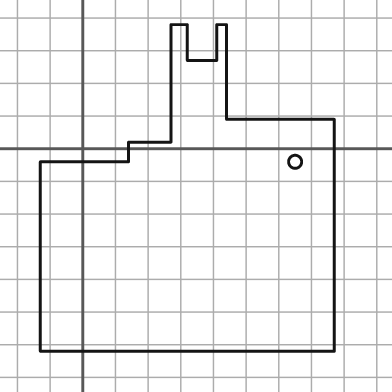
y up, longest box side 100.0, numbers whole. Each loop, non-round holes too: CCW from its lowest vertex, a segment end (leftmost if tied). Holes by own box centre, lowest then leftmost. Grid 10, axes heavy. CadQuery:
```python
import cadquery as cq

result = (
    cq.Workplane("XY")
    .moveTo(-13.0, -62.0)
    .lineTo(77.0, -62.0)
    .lineTo(77.0, 9.0)
    .lineTo(44.0, 9.0)
    .lineTo(44.0, 38.0)
    .lineTo(41.0, 38.0)
    .lineTo(41.0, 27.0)
    .lineTo(32.0, 27.0)
    .lineTo(32.0, 38.0)
    .lineTo(27.0, 38.0)
    .lineTo(27.0, 2.0)
    .lineTo(14.0, 2.0)
    .lineTo(14.0, -4.0)
    .lineTo(-13.0, -4.0)
    .close()
    .moveTo(65.0, -4.0)
    .circle(2.0)
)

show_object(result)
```